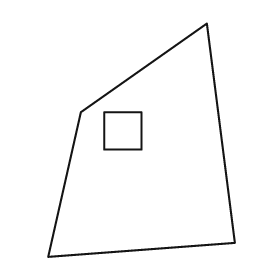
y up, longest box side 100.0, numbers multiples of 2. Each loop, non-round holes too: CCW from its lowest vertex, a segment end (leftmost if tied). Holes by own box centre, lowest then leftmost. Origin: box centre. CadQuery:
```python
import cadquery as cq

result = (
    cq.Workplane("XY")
    .moveTo(-40.0, -50.0)
    .lineTo(40.0, -44.0)
    .lineTo(28.0, 50.0)
    .lineTo(-26.0, 12.0)
    .close()
    .moveTo(-16.0, -4.0)
    .lineTo(0.0, -4.0)
    .lineTo(0.0, 12.0)
    .lineTo(-16.0, 12.0)
    .close()
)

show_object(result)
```